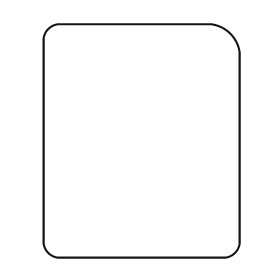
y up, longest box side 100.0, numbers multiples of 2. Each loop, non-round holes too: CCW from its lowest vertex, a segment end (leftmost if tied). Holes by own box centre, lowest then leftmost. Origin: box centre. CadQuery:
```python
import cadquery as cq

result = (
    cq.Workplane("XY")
    .moveTo(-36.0, -50.0)
    .lineTo(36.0, -50.0)
    .threePointArc((40.0, -48.0), (42.0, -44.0))
    .lineTo(42.0, 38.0)
    .threePointArc((38.0, 46.0), (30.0, 50.0))
    .lineTo(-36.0, 50.0)
    .threePointArc((-40.0, 48.0), (-42.0, 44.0))
    .lineTo(-42.0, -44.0)
    .threePointArc((-40.0, -48.0), (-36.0, -50.0))
    .close()
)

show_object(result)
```